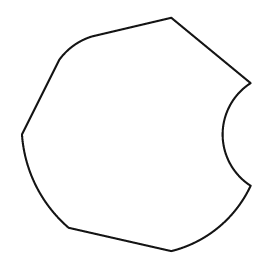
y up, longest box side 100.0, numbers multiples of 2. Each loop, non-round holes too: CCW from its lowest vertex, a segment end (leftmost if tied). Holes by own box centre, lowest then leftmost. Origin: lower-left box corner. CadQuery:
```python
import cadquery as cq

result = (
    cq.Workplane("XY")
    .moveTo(64.0, 0.0)
    .threePointArc((84.0, 10.0), (98.0, 28.0))
    .threePointArc((86.0, 50.0), (98.0, 72.0))
    .lineTo(64.0, 100.0)
    .lineTo(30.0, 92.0)
    .threePointArc((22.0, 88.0), (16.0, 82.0))
    .lineTo(0.0, 50.0)
    .threePointArc((6.0, 28.0), (20.0, 10.0))
    .close()
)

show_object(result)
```